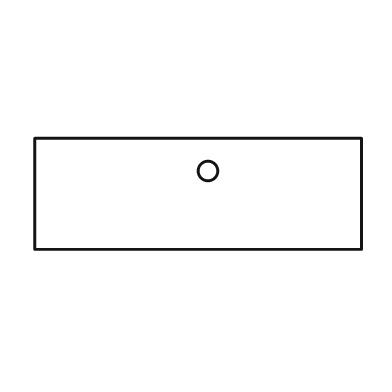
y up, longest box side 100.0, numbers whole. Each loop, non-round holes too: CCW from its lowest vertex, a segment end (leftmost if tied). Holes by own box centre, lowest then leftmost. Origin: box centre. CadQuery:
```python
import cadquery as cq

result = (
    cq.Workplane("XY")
    .moveTo(-50.0, -17.0)
    .lineTo(50.0, -17.0)
    .lineTo(50.0, 17.0)
    .lineTo(-50.0, 17.0)
    .close()
    .moveTo(3.0, 7.0)
    .circle(3.0)
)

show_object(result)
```